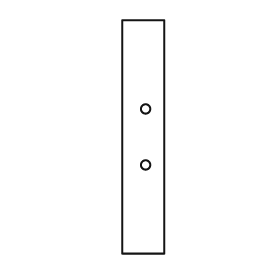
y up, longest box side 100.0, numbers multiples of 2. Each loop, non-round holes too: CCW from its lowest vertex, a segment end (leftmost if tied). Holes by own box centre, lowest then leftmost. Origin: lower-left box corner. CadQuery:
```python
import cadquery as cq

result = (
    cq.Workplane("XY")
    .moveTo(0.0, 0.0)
    .lineTo(18.0, 0.0)
    .lineTo(18.0, 100.0)
    .lineTo(0.0, 100.0)
    .close()
    .moveTo(10.0, 38.0)
    .circle(2.0)
    .moveTo(10.0, 62.0)
    .circle(2.0)
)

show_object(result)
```